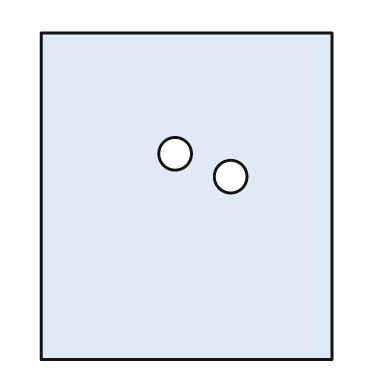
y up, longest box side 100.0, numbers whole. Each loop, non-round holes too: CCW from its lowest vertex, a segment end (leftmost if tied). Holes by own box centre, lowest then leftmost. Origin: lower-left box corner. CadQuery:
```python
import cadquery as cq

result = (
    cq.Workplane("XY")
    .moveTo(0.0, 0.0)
    .lineTo(89.0, 0.0)
    .lineTo(89.0, 100.0)
    .lineTo(0.0, 100.0)
    .close()
    .moveTo(58.0, 56.0)
    .circle(5.0)
    .moveTo(41.0, 63.0)
    .circle(5.0)
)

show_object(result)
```